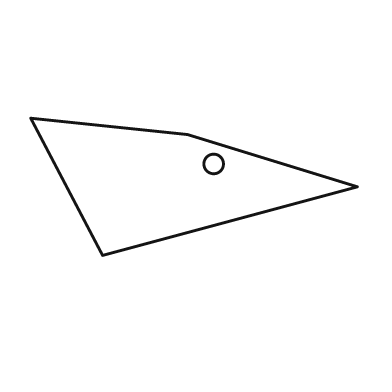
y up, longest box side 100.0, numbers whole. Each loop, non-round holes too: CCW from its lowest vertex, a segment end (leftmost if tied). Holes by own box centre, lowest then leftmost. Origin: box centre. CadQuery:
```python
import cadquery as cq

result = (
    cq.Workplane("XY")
    .moveTo(-28.0, -21.0)
    .lineTo(50.0, 0.0)
    .lineTo(-2.0, 16.0)
    .lineTo(-50.0, 21.0)
    .close()
    .moveTo(6.0, 7.0)
    .circle(3.0)
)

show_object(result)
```